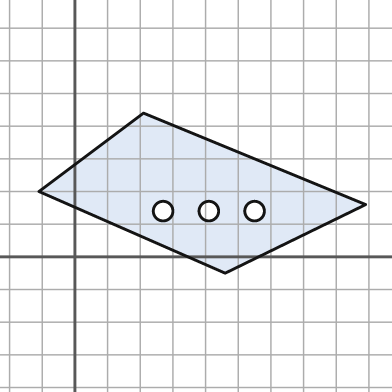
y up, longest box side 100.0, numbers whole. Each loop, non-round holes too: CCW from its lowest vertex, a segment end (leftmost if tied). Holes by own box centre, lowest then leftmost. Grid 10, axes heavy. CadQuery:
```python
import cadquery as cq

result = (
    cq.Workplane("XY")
    .moveTo(46.0, -5.0)
    .lineTo(89.0, 16.0)
    .lineTo(21.0, 44.0)
    .lineTo(-11.0, 20.0)
    .close()
    .moveTo(27.0, 14.0)
    .circle(3.0)
    .moveTo(41.0, 14.0)
    .circle(3.0)
    .moveTo(55.0, 14.0)
    .circle(3.0)
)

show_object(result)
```